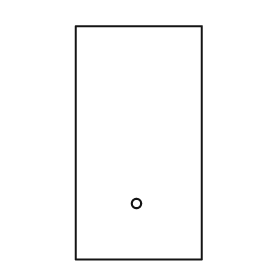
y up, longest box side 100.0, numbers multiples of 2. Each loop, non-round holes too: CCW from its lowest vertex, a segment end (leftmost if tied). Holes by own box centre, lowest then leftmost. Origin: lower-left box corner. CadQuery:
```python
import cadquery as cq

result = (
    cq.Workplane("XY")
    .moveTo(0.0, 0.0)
    .lineTo(54.0, 0.0)
    .lineTo(54.0, 100.0)
    .lineTo(0.0, 100.0)
    .close()
    .moveTo(26.0, 24.0)
    .circle(2.0)
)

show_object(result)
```